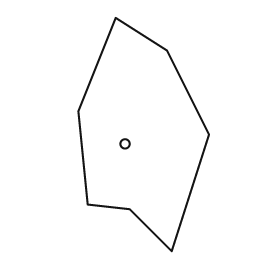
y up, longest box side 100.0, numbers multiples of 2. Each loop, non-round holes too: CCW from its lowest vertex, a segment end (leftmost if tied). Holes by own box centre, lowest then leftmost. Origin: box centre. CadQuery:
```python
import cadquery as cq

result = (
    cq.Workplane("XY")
    .moveTo(12.0, -50.0)
    .lineTo(28.0, 0.0)
    .lineTo(10.0, 36.0)
    .lineTo(-12.0, 50.0)
    .lineTo(-28.0, 10.0)
    .lineTo(-24.0, -30.0)
    .lineTo(-6.0, -32.0)
    .close()
    .moveTo(-8.0, -4.0)
    .circle(2.0)
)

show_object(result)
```